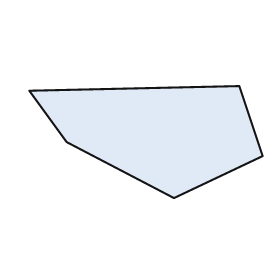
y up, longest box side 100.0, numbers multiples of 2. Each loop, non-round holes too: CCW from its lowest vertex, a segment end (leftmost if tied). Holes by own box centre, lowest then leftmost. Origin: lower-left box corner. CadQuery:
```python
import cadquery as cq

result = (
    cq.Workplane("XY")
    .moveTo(62.0, 0.0)
    .lineTo(100.0, 18.0)
    .lineTo(90.0, 48.0)
    .lineTo(0.0, 46.0)
    .lineTo(16.0, 24.0)
    .close()
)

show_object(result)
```